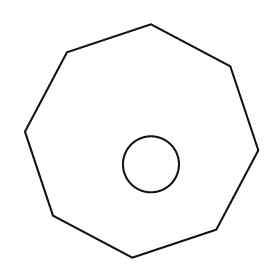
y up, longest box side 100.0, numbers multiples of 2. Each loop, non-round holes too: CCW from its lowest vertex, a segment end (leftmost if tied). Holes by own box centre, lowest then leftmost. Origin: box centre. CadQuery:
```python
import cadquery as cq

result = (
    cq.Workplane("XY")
    .moveTo(-4.0, -50.0)
    .lineTo(32.0, -38.0)
    .lineTo(50.0, -4.0)
    .lineTo(38.0, 32.0)
    .lineTo(4.0, 50.0)
    .lineTo(-32.0, 38.0)
    .lineTo(-50.0, 4.0)
    .lineTo(-38.0, -32.0)
    .close()
    .moveTo(4.0, -10.0)
    .circle(12.0)
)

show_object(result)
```